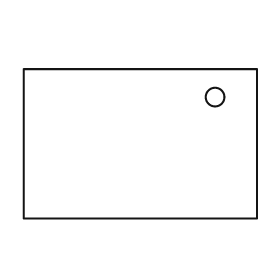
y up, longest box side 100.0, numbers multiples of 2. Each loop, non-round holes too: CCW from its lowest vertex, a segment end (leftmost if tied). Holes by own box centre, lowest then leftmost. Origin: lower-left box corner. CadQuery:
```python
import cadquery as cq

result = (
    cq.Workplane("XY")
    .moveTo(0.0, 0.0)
    .lineTo(100.0, 0.0)
    .lineTo(100.0, 64.0)
    .lineTo(0.0, 64.0)
    .close()
    .moveTo(82.0, 52.0)
    .circle(4.0)
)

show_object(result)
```